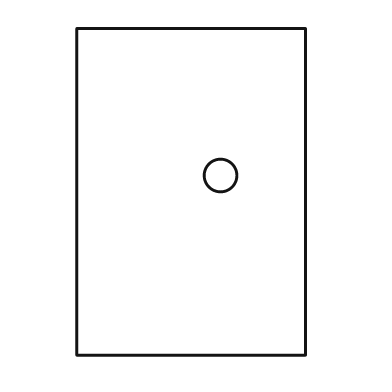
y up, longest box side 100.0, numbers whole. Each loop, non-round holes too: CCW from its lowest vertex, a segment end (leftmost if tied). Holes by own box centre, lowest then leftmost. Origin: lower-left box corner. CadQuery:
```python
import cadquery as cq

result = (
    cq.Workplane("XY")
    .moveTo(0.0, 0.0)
    .lineTo(70.0, 0.0)
    .lineTo(70.0, 100.0)
    .lineTo(0.0, 100.0)
    .close()
    .moveTo(44.0, 55.0)
    .circle(5.0)
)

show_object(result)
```